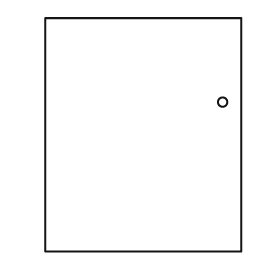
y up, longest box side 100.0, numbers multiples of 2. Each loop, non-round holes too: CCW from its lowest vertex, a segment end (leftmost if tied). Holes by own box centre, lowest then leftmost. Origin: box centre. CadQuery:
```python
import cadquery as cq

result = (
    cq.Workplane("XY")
    .moveTo(-42.0, -50.0)
    .lineTo(42.0, -50.0)
    .lineTo(42.0, 50.0)
    .lineTo(-42.0, 50.0)
    .close()
    .moveTo(34.0, 14.0)
    .circle(2.0)
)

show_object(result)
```